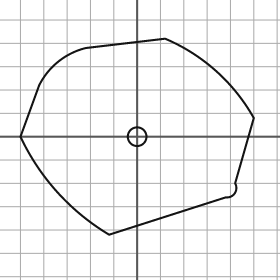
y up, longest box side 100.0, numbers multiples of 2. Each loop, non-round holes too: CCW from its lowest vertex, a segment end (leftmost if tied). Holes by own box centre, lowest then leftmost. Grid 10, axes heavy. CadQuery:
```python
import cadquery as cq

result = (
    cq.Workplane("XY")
    .moveTo(-12.0, -42.0)
    .lineTo(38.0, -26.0)
    .threePointArc((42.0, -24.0), (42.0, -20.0))
    .lineTo(50.0, 8.0)
    .threePointArc((34.0, 28.0), (12.0, 42.0))
    .lineTo(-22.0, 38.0)
    .threePointArc((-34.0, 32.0), (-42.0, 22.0))
    .lineTo(-50.0, 0.0)
    .threePointArc((-34.0, -24.0), (-12.0, -42.0))
    .close()
    .moveTo(0.0, 0.0)
    .circle(4.0)
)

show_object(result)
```